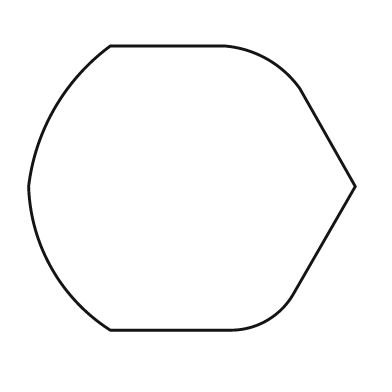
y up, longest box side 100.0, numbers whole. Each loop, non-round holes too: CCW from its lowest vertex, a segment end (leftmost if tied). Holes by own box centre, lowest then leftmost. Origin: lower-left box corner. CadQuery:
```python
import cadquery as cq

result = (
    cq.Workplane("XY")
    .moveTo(25.0, 0.0)
    .lineTo(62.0, 0.0)
    .threePointArc((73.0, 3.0), (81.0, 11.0))
    .lineTo(100.0, 44.0)
    .lineTo(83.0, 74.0)
    .threePointArc((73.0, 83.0), (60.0, 87.0))
    .lineTo(25.0, 87.0)
    .threePointArc((8.0, 68.0), (0.0, 44.0))
    .threePointArc((7.0, 19.0), (25.0, 0.0))
    .close()
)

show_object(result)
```